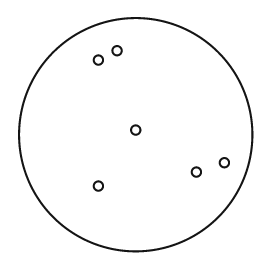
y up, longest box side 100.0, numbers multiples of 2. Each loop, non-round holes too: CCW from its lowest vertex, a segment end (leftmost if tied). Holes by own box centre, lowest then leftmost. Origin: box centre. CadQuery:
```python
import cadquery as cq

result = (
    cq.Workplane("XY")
    .moveTo(0.0, 0.0)
    .circle(50.0)
    .moveTo(-16.0, -22.0)
    .circle(2.0)
    .moveTo(26.0, -16.0)
    .circle(2.0)
    .moveTo(38.0, -12.0)
    .circle(2.0)
    .moveTo(0.0, 2.0)
    .circle(2.0)
    .moveTo(-16.0, 32.0)
    .circle(2.0)
    .moveTo(-8.0, 36.0)
    .circle(2.0)
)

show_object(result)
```